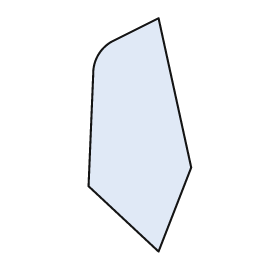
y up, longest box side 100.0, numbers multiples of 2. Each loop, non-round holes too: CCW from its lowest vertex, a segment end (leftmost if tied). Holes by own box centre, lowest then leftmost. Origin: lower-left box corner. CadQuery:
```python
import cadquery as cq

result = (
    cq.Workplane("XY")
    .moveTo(30.0, 0.0)
    .lineTo(44.0, 36.0)
    .lineTo(30.0, 100.0)
    .lineTo(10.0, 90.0)
    .threePointArc((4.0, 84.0), (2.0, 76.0))
    .lineTo(0.0, 28.0)
    .close()
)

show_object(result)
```